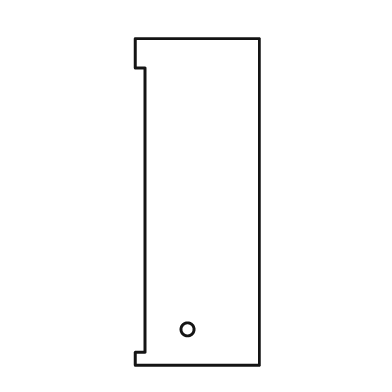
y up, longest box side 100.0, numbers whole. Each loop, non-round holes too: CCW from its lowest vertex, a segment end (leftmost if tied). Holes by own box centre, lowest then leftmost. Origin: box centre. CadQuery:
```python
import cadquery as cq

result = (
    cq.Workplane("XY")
    .moveTo(-19.0, -50.0)
    .lineTo(19.0, -50.0)
    .lineTo(19.0, 50.0)
    .lineTo(-19.0, 50.0)
    .lineTo(-19.0, 41.0)
    .lineTo(-16.0, 41.0)
    .lineTo(-16.0, -46.0)
    .lineTo(-19.0, -46.0)
    .close()
    .moveTo(-3.0, -39.0)
    .circle(2.0)
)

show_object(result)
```